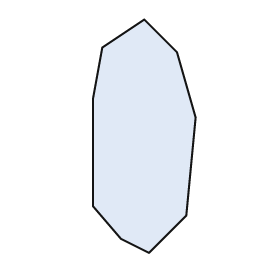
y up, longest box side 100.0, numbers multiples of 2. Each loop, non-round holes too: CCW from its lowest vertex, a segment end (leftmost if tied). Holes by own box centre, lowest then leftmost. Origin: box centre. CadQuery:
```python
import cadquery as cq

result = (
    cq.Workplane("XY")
    .moveTo(2.0, -50.0)
    .lineTo(18.0, -34.0)
    .lineTo(22.0, 8.0)
    .lineTo(14.0, 36.0)
    .lineTo(0.0, 50.0)
    .lineTo(-18.0, 38.0)
    .lineTo(-22.0, 16.0)
    .lineTo(-22.0, -30.0)
    .lineTo(-10.0, -44.0)
    .close()
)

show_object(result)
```